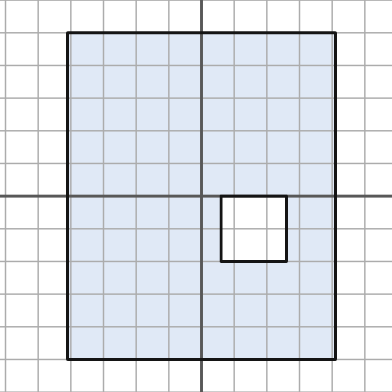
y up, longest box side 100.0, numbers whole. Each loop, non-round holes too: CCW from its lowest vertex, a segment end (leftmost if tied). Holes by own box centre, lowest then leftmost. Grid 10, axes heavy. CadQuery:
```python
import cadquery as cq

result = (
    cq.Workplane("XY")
    .moveTo(-41.0, -50.0)
    .lineTo(41.0, -50.0)
    .lineTo(41.0, 50.0)
    .lineTo(-41.0, 50.0)
    .close()
    .moveTo(6.0, -20.0)
    .lineTo(26.0, -20.0)
    .lineTo(26.0, 0.0)
    .lineTo(6.0, 0.0)
    .close()
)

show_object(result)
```